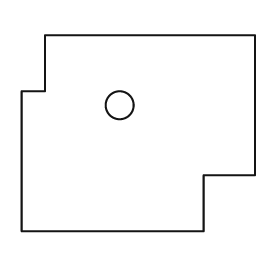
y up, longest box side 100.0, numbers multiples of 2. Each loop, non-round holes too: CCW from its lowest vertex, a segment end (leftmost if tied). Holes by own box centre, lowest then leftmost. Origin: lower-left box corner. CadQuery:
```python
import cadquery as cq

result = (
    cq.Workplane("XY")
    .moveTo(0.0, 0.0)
    .lineTo(78.0, 0.0)
    .lineTo(78.0, 24.0)
    .lineTo(100.0, 24.0)
    .lineTo(100.0, 84.0)
    .lineTo(10.0, 84.0)
    .lineTo(10.0, 60.0)
    .lineTo(0.0, 60.0)
    .close()
    .moveTo(42.0, 54.0)
    .circle(6.0)
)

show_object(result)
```